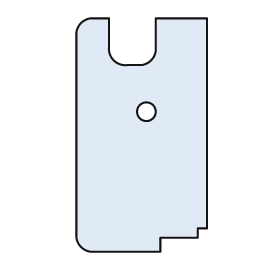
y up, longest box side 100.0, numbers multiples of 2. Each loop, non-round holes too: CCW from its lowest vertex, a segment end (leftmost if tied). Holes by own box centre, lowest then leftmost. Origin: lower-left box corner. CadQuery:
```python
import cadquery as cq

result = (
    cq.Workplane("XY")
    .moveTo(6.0, 0.0)
    .lineTo(36.0, 0.0)
    .lineTo(36.0, 6.0)
    .lineTo(52.0, 6.0)
    .lineTo(52.0, 10.0)
    .lineTo(56.0, 10.0)
    .lineTo(56.0, 100.0)
    .lineTo(34.0, 100.0)
    .lineTo(34.0, 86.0)
    .threePointArc((32.0, 82.0), (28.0, 80.0))
    .lineTo(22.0, 80.0)
    .threePointArc((16.0, 82.0), (14.0, 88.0))
    .lineTo(14.0, 100.0)
    .lineTo(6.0, 100.0)
    .threePointArc((2.0, 98.0), (0.0, 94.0))
    .lineTo(0.0, 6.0)
    .threePointArc((2.0, 2.0), (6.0, 0.0))
    .close()
    .moveTo(30.0, 60.0)
    .circle(4.0)
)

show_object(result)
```